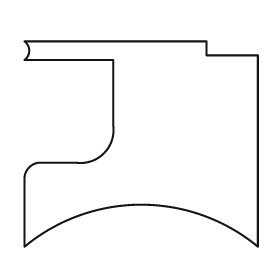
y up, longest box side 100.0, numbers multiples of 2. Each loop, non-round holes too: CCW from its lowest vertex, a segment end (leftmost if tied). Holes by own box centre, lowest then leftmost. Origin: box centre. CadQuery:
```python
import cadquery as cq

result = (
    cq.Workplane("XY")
    .moveTo(-50.0, -44.0)
    .threePointArc((0.0, -26.0), (50.0, -44.0))
    .lineTo(50.0, 38.0)
    .lineTo(28.0, 38.0)
    .lineTo(28.0, 44.0)
    .lineTo(-50.0, 44.0)
    .threePointArc((-48.0, 40.0), (-50.0, 36.0))
    .lineTo(-12.0, 36.0)
    .lineTo(-12.0, 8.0)
    .threePointArc((-16.0, -4.0), (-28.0, -8.0))
    .lineTo(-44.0, -8.0)
    .threePointArc((-48.0, -10.0), (-50.0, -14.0))
    .close()
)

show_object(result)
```